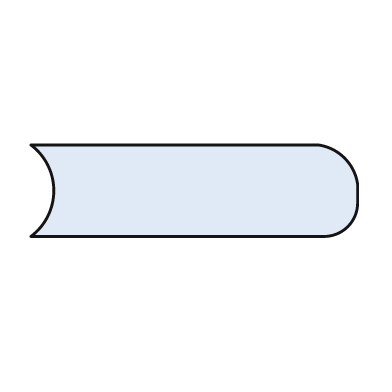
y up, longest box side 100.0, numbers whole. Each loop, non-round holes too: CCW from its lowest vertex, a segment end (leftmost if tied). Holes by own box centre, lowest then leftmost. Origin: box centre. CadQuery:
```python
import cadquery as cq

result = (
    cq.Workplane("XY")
    .moveTo(-50.0, -14.0)
    .lineTo(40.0, -14.0)
    .threePointArc((47.0, -11.0), (50.0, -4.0))
    .lineTo(50.0, 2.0)
    .threePointArc((46.0, 10.0), (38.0, 14.0))
    .lineTo(-50.0, 14.0)
    .threePointArc((-43.0, 0.0), (-50.0, -14.0))
    .close()
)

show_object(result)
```